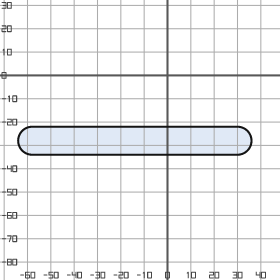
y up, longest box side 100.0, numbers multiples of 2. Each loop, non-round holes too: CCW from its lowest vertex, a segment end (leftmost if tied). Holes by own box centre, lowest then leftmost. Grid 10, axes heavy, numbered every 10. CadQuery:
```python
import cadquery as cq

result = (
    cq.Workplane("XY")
    .moveTo(-58.0, -34.0)
    .lineTo(30.0, -34.0)
    .threePointArc((36.0, -28.0), (30.0, -22.0))
    .lineTo(-58.0, -22.0)
    .threePointArc((-64.0, -28.0), (-58.0, -34.0))
    .close()
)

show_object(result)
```